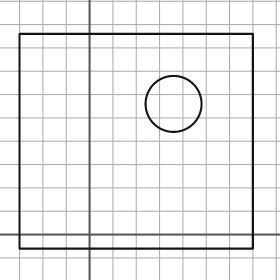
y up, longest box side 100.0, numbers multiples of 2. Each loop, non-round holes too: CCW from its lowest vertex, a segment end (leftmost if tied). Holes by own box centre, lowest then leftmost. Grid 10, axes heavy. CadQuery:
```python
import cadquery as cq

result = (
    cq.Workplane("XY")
    .moveTo(-30.0, -6.0)
    .lineTo(70.0, -6.0)
    .lineTo(70.0, 86.0)
    .lineTo(-30.0, 86.0)
    .close()
    .moveTo(36.0, 56.0)
    .circle(12.0)
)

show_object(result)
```